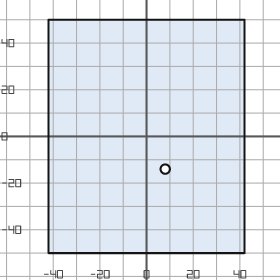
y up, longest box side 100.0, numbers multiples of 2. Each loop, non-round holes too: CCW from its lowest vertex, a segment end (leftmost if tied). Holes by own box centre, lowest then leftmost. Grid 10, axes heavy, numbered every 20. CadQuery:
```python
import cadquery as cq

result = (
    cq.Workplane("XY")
    .moveTo(-42.0, -50.0)
    .lineTo(42.0, -50.0)
    .lineTo(42.0, 50.0)
    .lineTo(-42.0, 50.0)
    .close()
    .moveTo(8.0, -14.0)
    .circle(2.0)
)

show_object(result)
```